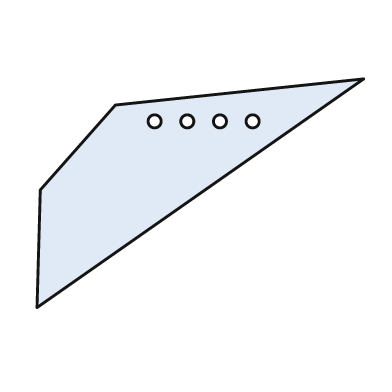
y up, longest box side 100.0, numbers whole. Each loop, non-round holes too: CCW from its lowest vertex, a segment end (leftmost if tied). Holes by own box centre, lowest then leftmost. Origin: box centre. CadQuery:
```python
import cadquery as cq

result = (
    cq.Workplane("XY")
    .moveTo(-50.0, -35.0)
    .lineTo(50.0, 35.0)
    .lineTo(-26.0, 27.0)
    .lineTo(-49.0, 1.0)
    .close()
    .moveTo(-14.0, 22.0)
    .circle(2.0)
    .moveTo(-4.0, 22.0)
    .circle(2.0)
    .moveTo(6.0, 22.0)
    .circle(2.0)
    .moveTo(16.0, 22.0)
    .circle(2.0)
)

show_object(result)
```